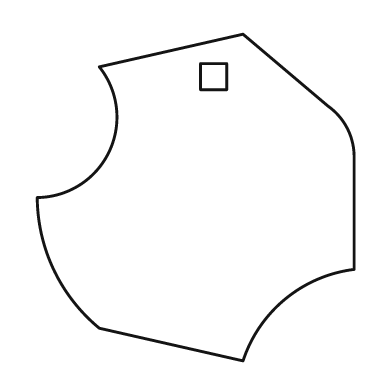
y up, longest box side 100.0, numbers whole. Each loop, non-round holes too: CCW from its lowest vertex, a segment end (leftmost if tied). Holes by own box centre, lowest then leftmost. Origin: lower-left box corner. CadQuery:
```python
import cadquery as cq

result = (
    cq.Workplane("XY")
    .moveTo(63.0, 0.0)
    .threePointArc((76.0, 19.0), (97.0, 28.0))
    .lineTo(97.0, 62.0)
    .threePointArc((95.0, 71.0), (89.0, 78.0))
    .lineTo(63.0, 100.0)
    .lineTo(19.0, 90.0)
    .threePointArc((22.0, 64.0), (0.0, 50.0))
    .threePointArc((5.0, 28.0), (19.0, 10.0))
    .close()
    .moveTo(50.0, 83.0)
    .lineTo(58.0, 83.0)
    .lineTo(58.0, 91.0)
    .lineTo(50.0, 91.0)
    .close()
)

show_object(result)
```